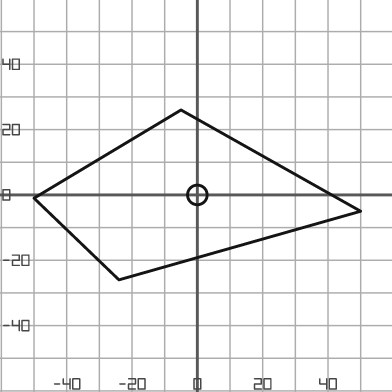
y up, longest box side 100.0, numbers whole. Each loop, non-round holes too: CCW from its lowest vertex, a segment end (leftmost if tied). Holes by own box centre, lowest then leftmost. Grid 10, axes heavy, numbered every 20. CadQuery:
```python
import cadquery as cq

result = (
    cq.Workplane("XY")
    .moveTo(-24.0, -26.0)
    .lineTo(50.0, -5.0)
    .lineTo(-5.0, 26.0)
    .lineTo(-50.0, -1.0)
    .close()
    .moveTo(0.0, 0.0)
    .circle(3.0)
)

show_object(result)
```